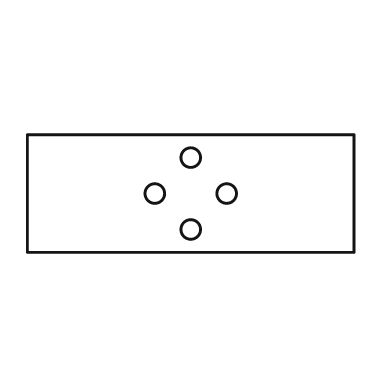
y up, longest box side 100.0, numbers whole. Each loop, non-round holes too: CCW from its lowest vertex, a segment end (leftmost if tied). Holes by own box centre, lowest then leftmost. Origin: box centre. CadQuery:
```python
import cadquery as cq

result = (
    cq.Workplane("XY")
    .moveTo(-50.0, -18.0)
    .lineTo(50.0, -18.0)
    .lineTo(50.0, 18.0)
    .lineTo(-50.0, 18.0)
    .close()
    .moveTo(0.0, -11.0)
    .circle(3.0)
    .moveTo(-11.0, 0.0)
    .circle(3.0)
    .moveTo(11.0, 0.0)
    .circle(3.0)
    .moveTo(0.0, 11.0)
    .circle(3.0)
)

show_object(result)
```